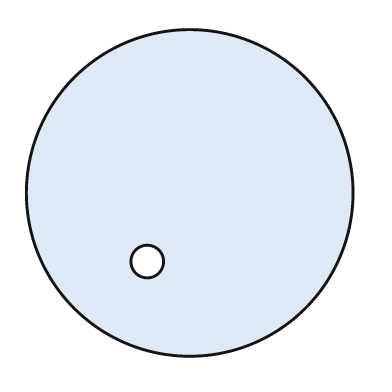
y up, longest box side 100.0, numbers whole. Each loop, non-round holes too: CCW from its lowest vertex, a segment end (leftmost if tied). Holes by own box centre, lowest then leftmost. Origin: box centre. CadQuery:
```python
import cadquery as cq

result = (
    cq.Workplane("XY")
    .moveTo(0.0, 0.0)
    .circle(50.0)
    .moveTo(-13.0, -21.0)
    .circle(5.0)
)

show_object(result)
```